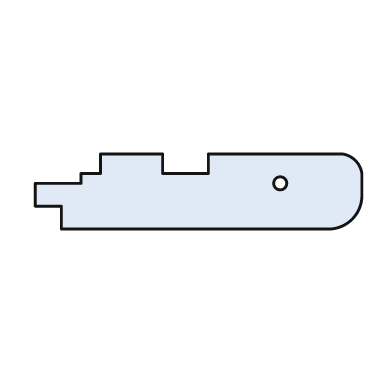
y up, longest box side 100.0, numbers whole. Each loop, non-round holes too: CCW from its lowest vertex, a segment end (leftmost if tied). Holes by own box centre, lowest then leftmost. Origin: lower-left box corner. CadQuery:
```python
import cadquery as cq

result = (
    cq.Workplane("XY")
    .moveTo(8.0, 0.0)
    .lineTo(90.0, 0.0)
    .threePointArc((97.0, 3.0), (100.0, 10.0))
    .lineTo(100.0, 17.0)
    .threePointArc((98.0, 21.0), (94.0, 23.0))
    .lineTo(53.0, 23.0)
    .lineTo(53.0, 17.0)
    .lineTo(39.0, 17.0)
    .lineTo(39.0, 23.0)
    .lineTo(20.0, 23.0)
    .lineTo(20.0, 17.0)
    .lineTo(14.0, 17.0)
    .lineTo(14.0, 14.0)
    .lineTo(0.0, 14.0)
    .lineTo(0.0, 7.0)
    .lineTo(8.0, 7.0)
    .close()
    .moveTo(75.0, 14.0)
    .circle(2.0)
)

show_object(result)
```